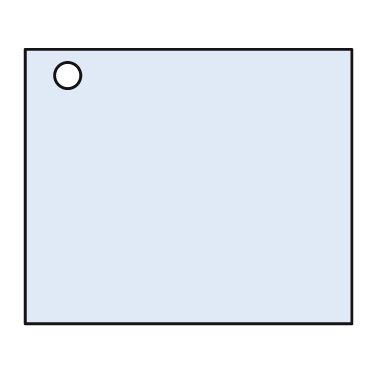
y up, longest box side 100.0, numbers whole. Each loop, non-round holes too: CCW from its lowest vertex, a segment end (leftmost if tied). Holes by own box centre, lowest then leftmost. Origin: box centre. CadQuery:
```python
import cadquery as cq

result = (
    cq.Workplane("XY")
    .moveTo(-50.0, -42.0)
    .lineTo(50.0, -42.0)
    .lineTo(50.0, 42.0)
    .lineTo(-50.0, 42.0)
    .close()
    .moveTo(-37.0, 34.0)
    .circle(4.0)
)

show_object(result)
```